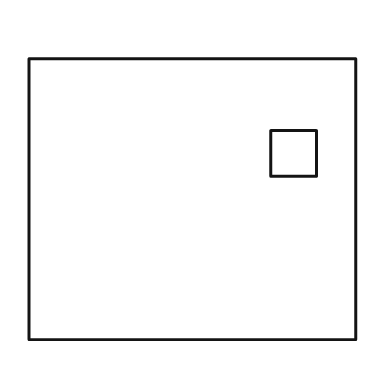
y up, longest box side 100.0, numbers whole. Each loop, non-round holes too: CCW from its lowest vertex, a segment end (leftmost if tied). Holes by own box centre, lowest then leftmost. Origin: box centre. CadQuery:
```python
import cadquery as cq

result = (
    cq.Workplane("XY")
    .moveTo(-50.0, -43.0)
    .lineTo(50.0, -43.0)
    .lineTo(50.0, 43.0)
    .lineTo(-50.0, 43.0)
    .close()
    .moveTo(24.0, 7.0)
    .lineTo(38.0, 7.0)
    .lineTo(38.0, 21.0)
    .lineTo(24.0, 21.0)
    .close()
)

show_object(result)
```